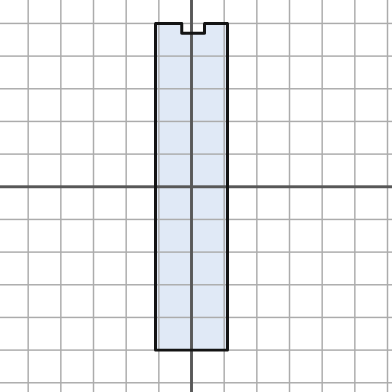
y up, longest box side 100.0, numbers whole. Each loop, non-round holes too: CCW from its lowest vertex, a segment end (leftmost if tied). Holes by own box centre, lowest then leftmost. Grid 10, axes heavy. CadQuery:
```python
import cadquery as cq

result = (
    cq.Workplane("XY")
    .moveTo(-11.0, -50.0)
    .lineTo(11.0, -50.0)
    .lineTo(11.0, 50.0)
    .lineTo(4.0, 50.0)
    .lineTo(4.0, 47.0)
    .lineTo(-3.0, 47.0)
    .lineTo(-3.0, 50.0)
    .lineTo(-11.0, 50.0)
    .close()
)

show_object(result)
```